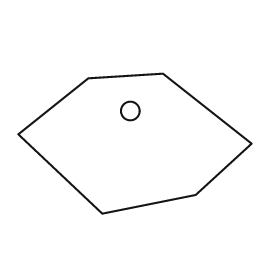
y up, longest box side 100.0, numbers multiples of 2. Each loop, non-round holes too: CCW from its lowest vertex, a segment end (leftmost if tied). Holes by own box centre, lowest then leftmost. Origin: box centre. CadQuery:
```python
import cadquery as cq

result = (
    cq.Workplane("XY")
    .moveTo(-14.0, -30.0)
    .lineTo(26.0, -22.0)
    .lineTo(50.0, 0.0)
    .lineTo(12.0, 30.0)
    .lineTo(-20.0, 28.0)
    .lineTo(-50.0, 4.0)
    .close()
    .moveTo(-2.0, 14.0)
    .circle(4.0)
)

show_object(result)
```